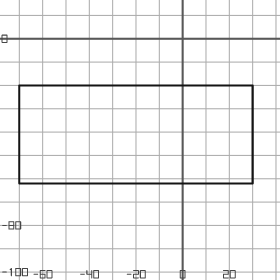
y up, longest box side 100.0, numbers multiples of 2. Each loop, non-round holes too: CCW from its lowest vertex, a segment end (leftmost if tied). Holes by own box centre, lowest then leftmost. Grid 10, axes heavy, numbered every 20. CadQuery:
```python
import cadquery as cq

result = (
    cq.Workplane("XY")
    .moveTo(-70.0, -62.0)
    .lineTo(30.0, -62.0)
    .lineTo(30.0, -20.0)
    .lineTo(-70.0, -20.0)
    .close()
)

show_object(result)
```